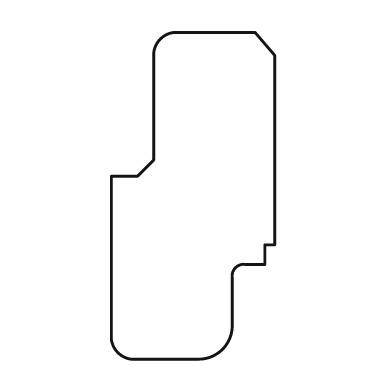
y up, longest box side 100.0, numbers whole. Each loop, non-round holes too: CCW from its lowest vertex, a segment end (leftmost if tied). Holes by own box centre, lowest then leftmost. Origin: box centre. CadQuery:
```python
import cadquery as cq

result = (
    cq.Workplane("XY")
    .moveTo(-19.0, -50.0)
    .lineTo(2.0, -50.0)
    .threePointArc((9.0, -47.0), (12.0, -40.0))
    .lineTo(12.0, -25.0)
    .threePointArc((13.0, -22.0), (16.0, -21.0))
    .lineTo(22.0, -21.0)
    .lineTo(22.0, -15.0)
    .lineTo(25.0, -15.0)
    .lineTo(25.0, 43.0)
    .lineTo(19.0, 50.0)
    .lineTo(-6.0, 50.0)
    .threePointArc((-10.0, 48.0), (-12.0, 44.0))
    .lineTo(-12.0, 11.0)
    .lineTo(-17.0, 6.0)
    .lineTo(-25.0, 6.0)
    .lineTo(-25.0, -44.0)
    .threePointArc((-23.0, -48.0), (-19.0, -50.0))
    .close()
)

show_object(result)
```